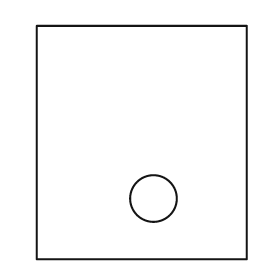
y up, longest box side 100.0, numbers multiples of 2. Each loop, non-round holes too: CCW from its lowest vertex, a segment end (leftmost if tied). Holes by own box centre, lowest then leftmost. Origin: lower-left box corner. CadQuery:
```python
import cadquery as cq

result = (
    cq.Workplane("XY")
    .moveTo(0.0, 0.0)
    .lineTo(90.0, 0.0)
    .lineTo(90.0, 100.0)
    .lineTo(0.0, 100.0)
    .close()
    .moveTo(50.0, 26.0)
    .circle(10.0)
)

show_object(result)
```